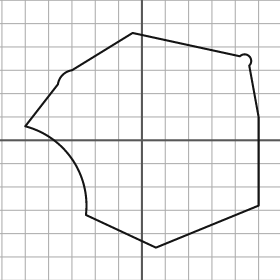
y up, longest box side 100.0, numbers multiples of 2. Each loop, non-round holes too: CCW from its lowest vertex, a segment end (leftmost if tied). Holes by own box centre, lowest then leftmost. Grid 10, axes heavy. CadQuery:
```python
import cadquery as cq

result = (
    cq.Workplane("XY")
    .moveTo(6.0, -46.0)
    .lineTo(50.0, -28.0)
    .lineTo(50.0, 10.0)
    .lineTo(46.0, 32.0)
    .threePointArc((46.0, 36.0), (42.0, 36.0))
    .lineTo(-4.0, 46.0)
    .lineTo(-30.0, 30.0)
    .threePointArc((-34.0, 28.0), (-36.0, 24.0))
    .lineTo(-50.0, 6.0)
    .threePointArc((-30.0, -8.0), (-24.0, -32.0))
    .close()
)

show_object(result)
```